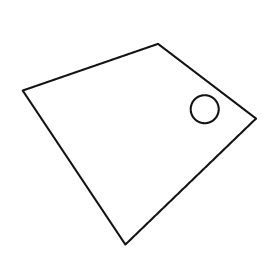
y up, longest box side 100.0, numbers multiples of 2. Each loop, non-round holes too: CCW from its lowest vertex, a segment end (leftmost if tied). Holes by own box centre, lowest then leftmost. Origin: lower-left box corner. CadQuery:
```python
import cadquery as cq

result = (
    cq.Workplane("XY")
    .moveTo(44.0, 0.0)
    .lineTo(100.0, 54.0)
    .lineTo(58.0, 86.0)
    .lineTo(0.0, 66.0)
    .close()
    .moveTo(78.0, 58.0)
    .circle(6.0)
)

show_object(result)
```